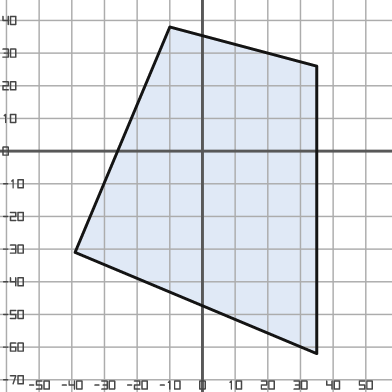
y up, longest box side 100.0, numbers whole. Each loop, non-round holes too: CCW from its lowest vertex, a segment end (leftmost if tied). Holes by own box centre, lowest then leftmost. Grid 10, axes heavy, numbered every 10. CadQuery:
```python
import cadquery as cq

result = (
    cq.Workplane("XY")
    .moveTo(35.0, -62.0)
    .lineTo(35.0, 26.0)
    .lineTo(-10.0, 38.0)
    .lineTo(-39.0, -31.0)
    .close()
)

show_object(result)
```